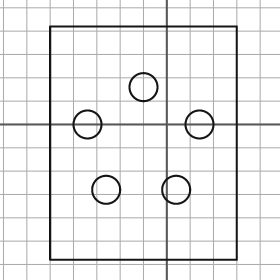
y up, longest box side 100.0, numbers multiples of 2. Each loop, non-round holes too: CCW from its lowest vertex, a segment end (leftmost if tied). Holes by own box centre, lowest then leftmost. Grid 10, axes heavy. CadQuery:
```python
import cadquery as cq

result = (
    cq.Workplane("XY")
    .moveTo(-50.0, -58.0)
    .lineTo(30.0, -58.0)
    .lineTo(30.0, 42.0)
    .lineTo(-50.0, 42.0)
    .close()
    .moveTo(-26.0, -28.0)
    .circle(6.0)
    .moveTo(4.0, -28.0)
    .circle(6.0)
    .moveTo(-34.0, 0.0)
    .circle(6.0)
    .moveTo(14.0, 0.0)
    .circle(6.0)
    .moveTo(-10.0, 16.0)
    .circle(6.0)
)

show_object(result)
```